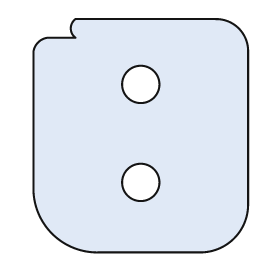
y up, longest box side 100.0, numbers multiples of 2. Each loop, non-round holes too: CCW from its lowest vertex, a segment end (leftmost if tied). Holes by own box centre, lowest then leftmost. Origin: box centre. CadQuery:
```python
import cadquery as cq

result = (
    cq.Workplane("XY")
    .moveTo(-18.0, -50.0)
    .lineTo(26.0, -50.0)
    .threePointArc((40.0, -44.0), (46.0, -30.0))
    .lineTo(46.0, 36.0)
    .threePointArc((42.0, 46.0), (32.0, 50.0))
    .lineTo(-28.0, 50.0)
    .threePointArc((-30.0, 46.0), (-28.0, 42.0))
    .lineTo(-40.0, 42.0)
    .threePointArc((-44.0, 40.0), (-46.0, 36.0))
    .lineTo(-46.0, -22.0)
    .threePointArc((-38.0, -42.0), (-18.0, -50.0))
    .close()
    .moveTo(0.0, -20.0)
    .circle(8.0)
    .moveTo(0.0, 22.0)
    .circle(8.0)
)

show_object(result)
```